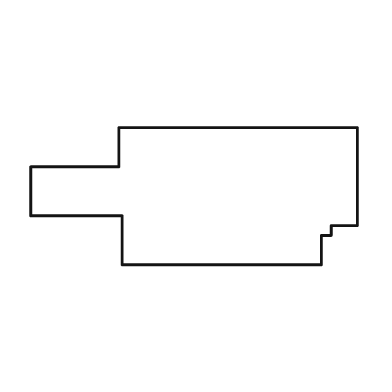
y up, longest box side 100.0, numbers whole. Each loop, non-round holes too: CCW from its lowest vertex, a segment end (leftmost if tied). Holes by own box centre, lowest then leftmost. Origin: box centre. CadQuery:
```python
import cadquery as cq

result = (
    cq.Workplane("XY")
    .moveTo(-22.0, -21.0)
    .lineTo(39.0, -21.0)
    .lineTo(39.0, -12.0)
    .lineTo(42.0, -12.0)
    .lineTo(42.0, -9.0)
    .lineTo(50.0, -9.0)
    .lineTo(50.0, 21.0)
    .lineTo(-23.0, 21.0)
    .lineTo(-23.0, 9.0)
    .lineTo(-50.0, 9.0)
    .lineTo(-50.0, -6.0)
    .lineTo(-22.0, -6.0)
    .close()
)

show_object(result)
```